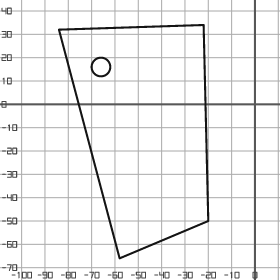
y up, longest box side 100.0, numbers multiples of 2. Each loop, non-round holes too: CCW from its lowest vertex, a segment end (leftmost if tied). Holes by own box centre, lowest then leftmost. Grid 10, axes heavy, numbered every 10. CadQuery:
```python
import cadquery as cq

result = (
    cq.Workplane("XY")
    .moveTo(-58.0, -66.0)
    .lineTo(-20.0, -50.0)
    .lineTo(-22.0, 34.0)
    .lineTo(-84.0, 32.0)
    .close()
    .moveTo(-66.0, 16.0)
    .circle(4.0)
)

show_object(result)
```